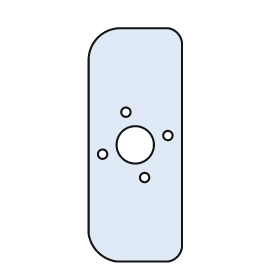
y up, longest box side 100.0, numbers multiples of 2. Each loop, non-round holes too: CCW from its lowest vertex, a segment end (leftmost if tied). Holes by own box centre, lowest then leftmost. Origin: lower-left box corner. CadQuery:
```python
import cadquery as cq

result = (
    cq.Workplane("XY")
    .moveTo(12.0, 0.0)
    .lineTo(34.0, 0.0)
    .threePointArc((38.0, 2.0), (40.0, 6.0))
    .lineTo(40.0, 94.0)
    .threePointArc((38.0, 98.0), (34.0, 100.0))
    .lineTo(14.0, 100.0)
    .threePointArc((4.0, 96.0), (0.0, 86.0))
    .lineTo(0.0, 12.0)
    .threePointArc((4.0, 4.0), (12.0, 0.0))
    .close()
    .moveTo(24.0, 36.0)
    .circle(2.0)
    .moveTo(6.0, 46.0)
    .circle(2.0)
    .moveTo(20.0, 50.0)
    .circle(8.0)
    .moveTo(34.0, 54.0)
    .circle(2.0)
    .moveTo(16.0, 64.0)
    .circle(2.0)
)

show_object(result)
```